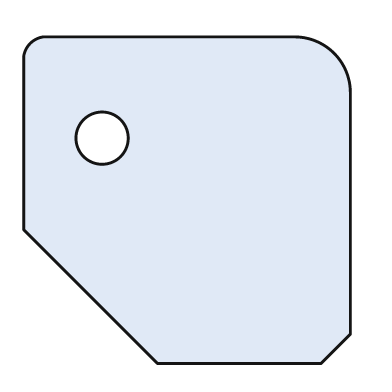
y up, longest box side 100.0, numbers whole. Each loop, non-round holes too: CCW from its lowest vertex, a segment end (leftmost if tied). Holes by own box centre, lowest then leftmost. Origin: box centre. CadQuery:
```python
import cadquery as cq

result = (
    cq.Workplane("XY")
    .moveTo(-9.0, -50.0)
    .lineTo(41.0, -50.0)
    .lineTo(50.0, -41.0)
    .lineTo(50.0, 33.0)
    .threePointArc((45.0, 45.0), (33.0, 50.0))
    .lineTo(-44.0, 50.0)
    .threePointArc((-48.0, 48.0), (-50.0, 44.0))
    .lineTo(-50.0, -9.0)
    .close()
    .moveTo(-26.0, 19.0)
    .circle(8.0)
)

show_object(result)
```